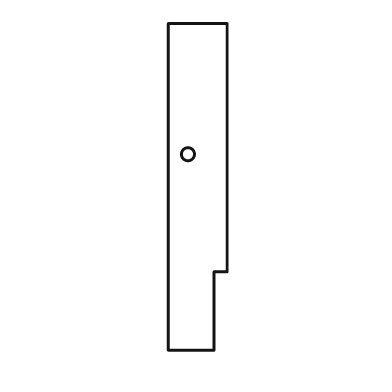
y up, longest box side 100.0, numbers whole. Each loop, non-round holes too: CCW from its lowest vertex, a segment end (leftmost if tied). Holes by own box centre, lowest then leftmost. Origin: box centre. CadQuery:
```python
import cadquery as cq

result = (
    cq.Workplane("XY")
    .moveTo(-9.0, -50.0)
    .lineTo(5.0, -50.0)
    .lineTo(5.0, -26.0)
    .lineTo(9.0, -26.0)
    .lineTo(9.0, 50.0)
    .lineTo(-9.0, 50.0)
    .close()
    .moveTo(-3.0, 10.0)
    .circle(2.0)
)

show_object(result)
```